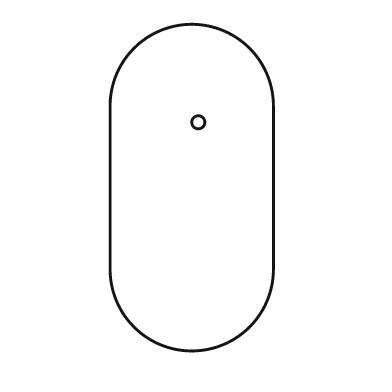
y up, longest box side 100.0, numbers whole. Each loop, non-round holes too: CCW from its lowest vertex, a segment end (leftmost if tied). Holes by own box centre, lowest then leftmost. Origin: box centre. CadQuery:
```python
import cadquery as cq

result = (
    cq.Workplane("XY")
    .moveTo(-25.0, -25.0)
    .threePointArc((0.0, -50.0), (25.0, -25.0))
    .lineTo(25.0, 25.0)
    .threePointArc((0.0, 50.0), (-25.0, 25.0))
    .close()
    .moveTo(2.0, 20.0)
    .circle(2.0)
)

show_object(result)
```